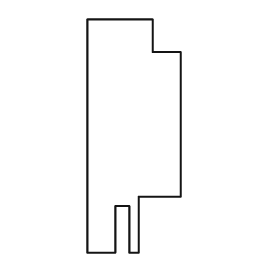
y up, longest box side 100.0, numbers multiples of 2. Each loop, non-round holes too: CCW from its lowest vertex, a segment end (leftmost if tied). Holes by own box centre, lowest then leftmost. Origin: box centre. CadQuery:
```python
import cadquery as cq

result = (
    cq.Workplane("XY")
    .moveTo(-20.0, -50.0)
    .lineTo(-8.0, -50.0)
    .lineTo(-8.0, -30.0)
    .lineTo(-2.0, -30.0)
    .lineTo(-2.0, -50.0)
    .lineTo(2.0, -50.0)
    .lineTo(2.0, -26.0)
    .lineTo(20.0, -26.0)
    .lineTo(20.0, 36.0)
    .lineTo(8.0, 36.0)
    .lineTo(8.0, 50.0)
    .lineTo(-20.0, 50.0)
    .close()
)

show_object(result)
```